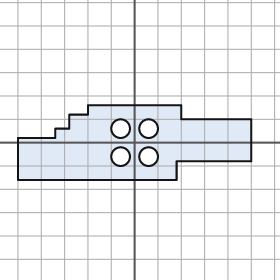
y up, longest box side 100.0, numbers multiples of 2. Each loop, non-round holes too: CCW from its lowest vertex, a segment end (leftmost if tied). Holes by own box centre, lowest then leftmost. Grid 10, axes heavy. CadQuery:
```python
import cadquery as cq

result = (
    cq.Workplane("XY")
    .moveTo(-50.0, -16.0)
    .lineTo(18.0, -16.0)
    .lineTo(18.0, -8.0)
    .lineTo(50.0, -8.0)
    .lineTo(50.0, 10.0)
    .lineTo(20.0, 10.0)
    .lineTo(20.0, 16.0)
    .lineTo(-20.0, 16.0)
    .lineTo(-20.0, 12.0)
    .lineTo(-28.0, 12.0)
    .lineTo(-28.0, 6.0)
    .lineTo(-34.0, 6.0)
    .lineTo(-34.0, 2.0)
    .lineTo(-50.0, 2.0)
    .close()
    .moveTo(-6.0, -6.0)
    .circle(4.0)
    .moveTo(6.0, -6.0)
    .circle(4.0)
    .moveTo(-6.0, 6.0)
    .circle(4.0)
    .moveTo(6.0, 6.0)
    .circle(4.0)
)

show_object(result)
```